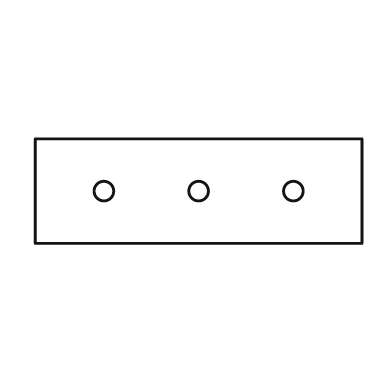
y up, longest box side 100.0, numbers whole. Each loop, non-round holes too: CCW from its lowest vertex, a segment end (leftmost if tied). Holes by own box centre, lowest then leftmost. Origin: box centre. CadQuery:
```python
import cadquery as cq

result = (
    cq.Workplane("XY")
    .moveTo(-50.0, -16.0)
    .lineTo(50.0, -16.0)
    .lineTo(50.0, 16.0)
    .lineTo(-50.0, 16.0)
    .close()
    .moveTo(-29.0, 0.0)
    .circle(3.0)
    .moveTo(0.0, 0.0)
    .circle(3.0)
    .moveTo(29.0, 0.0)
    .circle(3.0)
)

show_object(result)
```